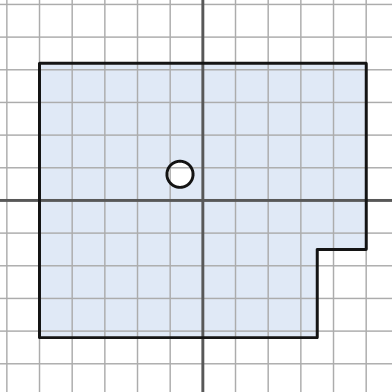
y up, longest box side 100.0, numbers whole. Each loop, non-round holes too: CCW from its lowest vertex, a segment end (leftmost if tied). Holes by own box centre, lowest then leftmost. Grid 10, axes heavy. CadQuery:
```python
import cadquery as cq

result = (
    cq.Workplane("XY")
    .moveTo(-50.0, -42.0)
    .lineTo(35.0, -42.0)
    .lineTo(35.0, -15.0)
    .lineTo(50.0, -15.0)
    .lineTo(50.0, 42.0)
    .lineTo(-50.0, 42.0)
    .close()
    .moveTo(-7.0, 8.0)
    .circle(4.0)
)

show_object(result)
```